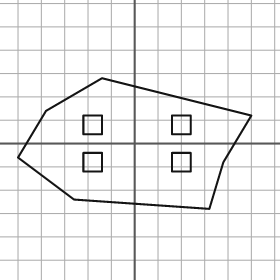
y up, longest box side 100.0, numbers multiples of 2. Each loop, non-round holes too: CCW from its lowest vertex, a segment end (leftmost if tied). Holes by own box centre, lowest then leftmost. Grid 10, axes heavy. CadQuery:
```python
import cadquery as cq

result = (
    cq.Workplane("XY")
    .moveTo(32.0, -28.0)
    .lineTo(38.0, -8.0)
    .lineTo(50.0, 12.0)
    .lineTo(-14.0, 28.0)
    .lineTo(-38.0, 14.0)
    .lineTo(-50.0, -6.0)
    .lineTo(-26.0, -24.0)
    .close()
    .moveTo(-22.0, -12.0)
    .lineTo(-14.0, -12.0)
    .lineTo(-14.0, -4.0)
    .lineTo(-22.0, -4.0)
    .close()
    .moveTo(16.0, -12.0)
    .lineTo(24.0, -12.0)
    .lineTo(24.0, -4.0)
    .lineTo(16.0, -4.0)
    .close()
    .moveTo(-22.0, 4.0)
    .lineTo(-14.0, 4.0)
    .lineTo(-14.0, 12.0)
    .lineTo(-22.0, 12.0)
    .close()
    .moveTo(16.0, 4.0)
    .lineTo(24.0, 4.0)
    .lineTo(24.0, 12.0)
    .lineTo(16.0, 12.0)
    .close()
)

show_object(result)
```